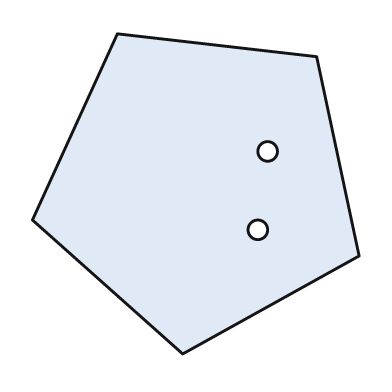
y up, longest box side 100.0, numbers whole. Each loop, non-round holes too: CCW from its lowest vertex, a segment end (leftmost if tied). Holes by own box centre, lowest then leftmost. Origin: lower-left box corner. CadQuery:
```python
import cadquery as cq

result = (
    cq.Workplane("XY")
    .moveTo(46.0, 0.0)
    .lineTo(100.0, 30.0)
    .lineTo(87.0, 91.0)
    .lineTo(26.0, 98.0)
    .lineTo(0.0, 41.0)
    .close()
    .moveTo(69.0, 38.0)
    .circle(3.0)
    .moveTo(72.0, 62.0)
    .circle(3.0)
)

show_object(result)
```